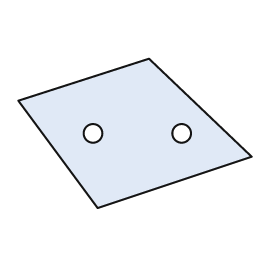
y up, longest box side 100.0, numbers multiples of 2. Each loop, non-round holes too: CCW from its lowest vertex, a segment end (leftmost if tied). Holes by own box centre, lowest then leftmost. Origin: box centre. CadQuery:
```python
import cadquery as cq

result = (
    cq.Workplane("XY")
    .moveTo(-16.0, -32.0)
    .lineTo(50.0, -10.0)
    .lineTo(6.0, 32.0)
    .lineTo(-50.0, 14.0)
    .close()
    .moveTo(-18.0, 0.0)
    .circle(4.0)
    .moveTo(20.0, 0.0)
    .circle(4.0)
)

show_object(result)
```